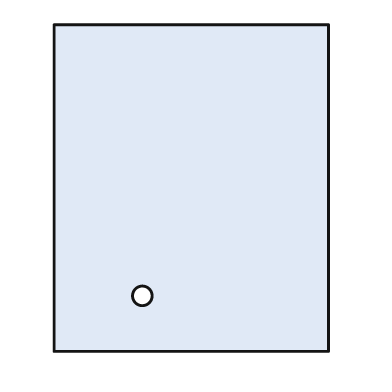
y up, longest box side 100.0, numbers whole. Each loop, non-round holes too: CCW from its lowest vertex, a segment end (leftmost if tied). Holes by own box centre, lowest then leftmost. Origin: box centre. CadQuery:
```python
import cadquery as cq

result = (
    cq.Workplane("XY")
    .moveTo(-42.0, -50.0)
    .lineTo(42.0, -50.0)
    .lineTo(42.0, 50.0)
    .lineTo(-42.0, 50.0)
    .close()
    .moveTo(-15.0, -33.0)
    .circle(3.0)
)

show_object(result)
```